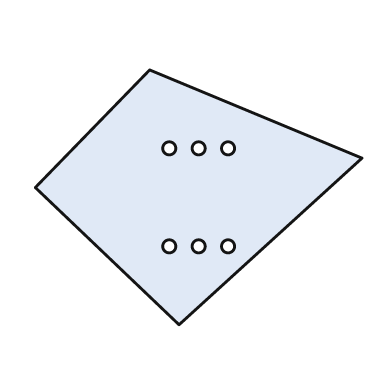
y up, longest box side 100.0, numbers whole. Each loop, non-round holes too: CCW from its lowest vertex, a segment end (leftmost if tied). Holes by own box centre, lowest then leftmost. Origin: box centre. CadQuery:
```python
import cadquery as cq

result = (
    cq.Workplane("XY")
    .moveTo(-6.0, -39.0)
    .lineTo(50.0, 12.0)
    .lineTo(-15.0, 39.0)
    .lineTo(-50.0, 3.0)
    .close()
    .moveTo(-9.0, -15.0)
    .circle(2.0)
    .moveTo(0.0, -15.0)
    .circle(2.0)
    .moveTo(9.0, -15.0)
    .circle(2.0)
    .moveTo(-9.0, 15.0)
    .circle(2.0)
    .moveTo(0.0, 15.0)
    .circle(2.0)
    .moveTo(9.0, 15.0)
    .circle(2.0)
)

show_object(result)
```